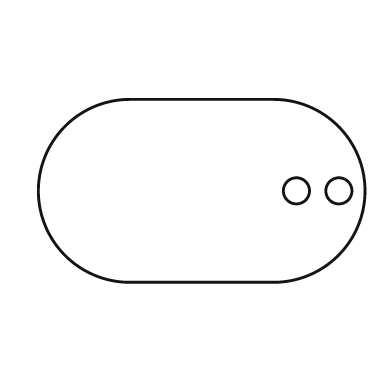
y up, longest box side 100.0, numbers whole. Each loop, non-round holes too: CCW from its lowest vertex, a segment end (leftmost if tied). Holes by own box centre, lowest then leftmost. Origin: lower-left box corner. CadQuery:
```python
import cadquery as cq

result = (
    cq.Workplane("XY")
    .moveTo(28.0, 0.0)
    .lineTo(72.0, 0.0)
    .threePointArc((100.0, 28.0), (72.0, 56.0))
    .lineTo(28.0, 56.0)
    .threePointArc((0.0, 28.0), (28.0, 0.0))
    .close()
    .moveTo(79.0, 28.0)
    .circle(4.0)
    .moveTo(92.0, 28.0)
    .circle(4.0)
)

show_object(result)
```